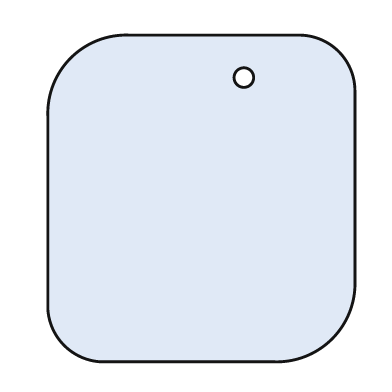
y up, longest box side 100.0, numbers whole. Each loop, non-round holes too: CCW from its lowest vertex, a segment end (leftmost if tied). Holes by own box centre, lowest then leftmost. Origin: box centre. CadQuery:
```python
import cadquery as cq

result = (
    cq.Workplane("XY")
    .moveTo(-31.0, -50.0)
    .lineTo(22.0, -50.0)
    .threePointArc((40.0, -43.0), (47.0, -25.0))
    .lineTo(47.0, 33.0)
    .threePointArc((42.0, 45.0), (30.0, 50.0))
    .lineTo(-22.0, 50.0)
    .threePointArc((-40.0, 43.0), (-47.0, 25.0))
    .lineTo(-47.0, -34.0)
    .threePointArc((-42.0, -45.0), (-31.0, -50.0))
    .close()
    .moveTo(13.0, 37.0)
    .circle(3.0)
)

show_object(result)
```